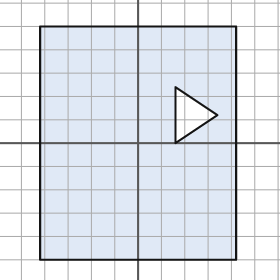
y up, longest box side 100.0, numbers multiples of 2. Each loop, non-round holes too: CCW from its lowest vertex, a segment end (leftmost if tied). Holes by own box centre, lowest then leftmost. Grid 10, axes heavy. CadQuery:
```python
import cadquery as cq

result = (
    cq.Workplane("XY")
    .moveTo(-42.0, -50.0)
    .lineTo(42.0, -50.0)
    .lineTo(42.0, 50.0)
    .lineTo(-42.0, 50.0)
    .close()
    .moveTo(16.0, 0.0)
    .lineTo(34.0, 12.0)
    .lineTo(16.0, 24.0)
    .close()
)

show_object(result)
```